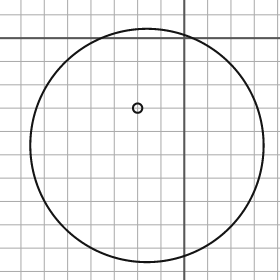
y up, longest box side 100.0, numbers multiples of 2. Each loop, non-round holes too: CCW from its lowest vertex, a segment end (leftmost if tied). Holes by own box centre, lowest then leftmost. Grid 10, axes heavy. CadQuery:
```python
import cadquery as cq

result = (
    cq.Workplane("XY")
    .moveTo(-16.0, -46.0)
    .circle(50.0)
    .moveTo(-20.0, -30.0)
    .circle(2.0)
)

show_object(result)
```